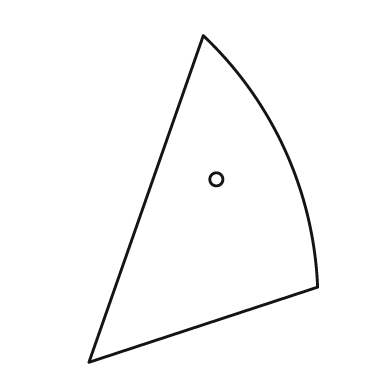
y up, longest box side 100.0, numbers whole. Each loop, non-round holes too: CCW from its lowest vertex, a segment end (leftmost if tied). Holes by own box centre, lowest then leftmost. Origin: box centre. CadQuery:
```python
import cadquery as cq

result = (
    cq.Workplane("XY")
    .moveTo(-35.0, -50.0)
    .lineTo(35.0, -27.0)
    .threePointArc((25.0, 15.0), (0.0, 50.0))
    .close()
    .moveTo(4.0, 6.0)
    .circle(2.0)
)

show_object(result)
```